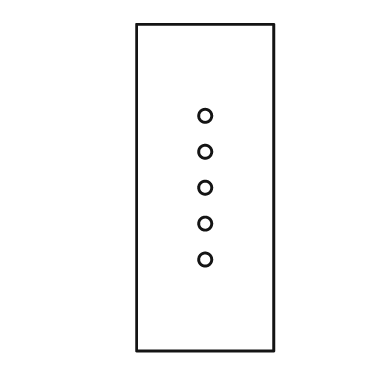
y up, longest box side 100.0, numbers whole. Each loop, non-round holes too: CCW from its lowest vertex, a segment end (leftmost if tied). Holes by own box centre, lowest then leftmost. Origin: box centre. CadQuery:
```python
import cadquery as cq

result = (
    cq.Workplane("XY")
    .moveTo(-21.0, -50.0)
    .lineTo(21.0, -50.0)
    .lineTo(21.0, 50.0)
    .lineTo(-21.0, 50.0)
    .close()
    .moveTo(0.0, -22.0)
    .circle(2.0)
    .moveTo(0.0, -11.0)
    .circle(2.0)
    .moveTo(0.0, 0.0)
    .circle(2.0)
    .moveTo(0.0, 11.0)
    .circle(2.0)
    .moveTo(0.0, 22.0)
    .circle(2.0)
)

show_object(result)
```